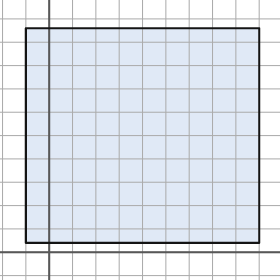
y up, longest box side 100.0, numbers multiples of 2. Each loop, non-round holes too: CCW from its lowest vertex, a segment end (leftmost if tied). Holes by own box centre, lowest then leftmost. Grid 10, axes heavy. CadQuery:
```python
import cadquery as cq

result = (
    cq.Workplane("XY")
    .moveTo(-10.0, 4.0)
    .lineTo(90.0, 4.0)
    .lineTo(90.0, 96.0)
    .lineTo(-10.0, 96.0)
    .close()
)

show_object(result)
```